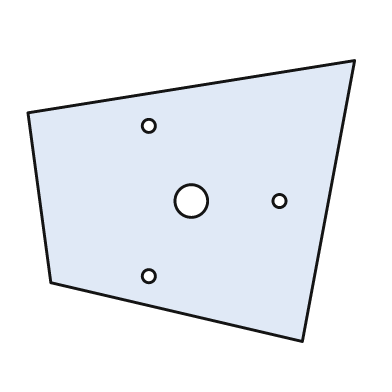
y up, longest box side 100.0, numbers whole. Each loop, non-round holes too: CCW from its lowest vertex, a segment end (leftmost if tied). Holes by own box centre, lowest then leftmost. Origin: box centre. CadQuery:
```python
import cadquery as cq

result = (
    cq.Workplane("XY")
    .moveTo(34.0, -43.0)
    .lineTo(50.0, 43.0)
    .lineTo(-50.0, 27.0)
    .lineTo(-43.0, -25.0)
    .close()
    .moveTo(-13.0, -23.0)
    .circle(2.0)
    .moveTo(0.0, 0.0)
    .circle(5.0)
    .moveTo(27.0, 0.0)
    .circle(2.0)
    .moveTo(-13.0, 23.0)
    .circle(2.0)
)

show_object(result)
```